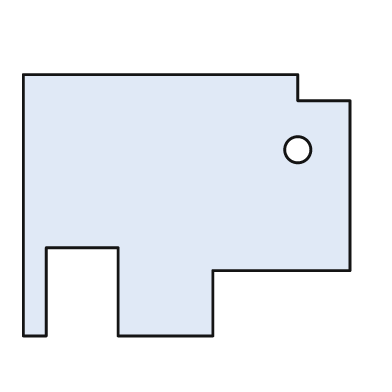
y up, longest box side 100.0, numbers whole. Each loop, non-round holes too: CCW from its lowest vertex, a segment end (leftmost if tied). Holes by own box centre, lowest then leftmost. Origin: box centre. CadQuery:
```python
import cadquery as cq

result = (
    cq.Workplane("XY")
    .moveTo(-50.0, -40.0)
    .lineTo(-43.0, -40.0)
    .lineTo(-43.0, -13.0)
    .lineTo(-21.0, -13.0)
    .lineTo(-21.0, -40.0)
    .lineTo(8.0, -40.0)
    .lineTo(8.0, -20.0)
    .lineTo(50.0, -20.0)
    .lineTo(50.0, 32.0)
    .lineTo(34.0, 32.0)
    .lineTo(34.0, 40.0)
    .lineTo(-50.0, 40.0)
    .close()
    .moveTo(34.0, 17.0)
    .circle(4.0)
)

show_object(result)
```